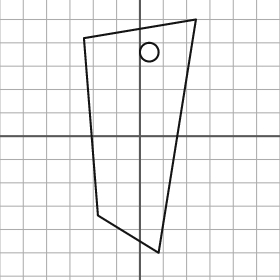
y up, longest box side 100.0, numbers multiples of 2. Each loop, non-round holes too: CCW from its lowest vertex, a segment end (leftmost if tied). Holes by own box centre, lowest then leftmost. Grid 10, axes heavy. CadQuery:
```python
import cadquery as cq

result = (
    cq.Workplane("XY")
    .moveTo(8.0, -50.0)
    .lineTo(24.0, 50.0)
    .lineTo(-24.0, 42.0)
    .lineTo(-18.0, -34.0)
    .close()
    .moveTo(4.0, 36.0)
    .circle(4.0)
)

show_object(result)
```